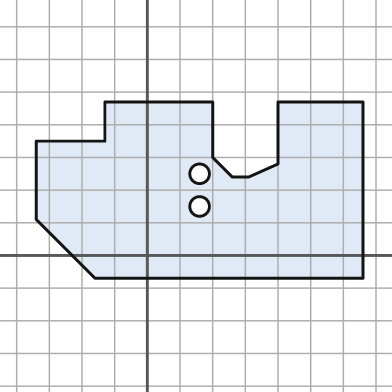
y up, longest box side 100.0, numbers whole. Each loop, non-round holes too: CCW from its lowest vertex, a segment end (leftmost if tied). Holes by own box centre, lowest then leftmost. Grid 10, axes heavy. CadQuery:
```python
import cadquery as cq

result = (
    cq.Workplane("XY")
    .moveTo(-16.0, -7.0)
    .lineTo(66.0, -7.0)
    .lineTo(66.0, 47.0)
    .lineTo(40.0, 47.0)
    .lineTo(40.0, 28.0)
    .lineTo(31.0, 24.0)
    .lineTo(26.0, 24.0)
    .lineTo(20.0, 30.0)
    .lineTo(20.0, 47.0)
    .lineTo(-13.0, 47.0)
    .lineTo(-13.0, 35.0)
    .lineTo(-34.0, 35.0)
    .lineTo(-34.0, 11.0)
    .close()
    .moveTo(16.0, 15.0)
    .circle(3.0)
    .moveTo(16.0, 25.0)
    .circle(3.0)
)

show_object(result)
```